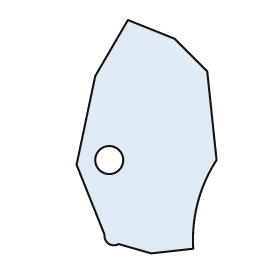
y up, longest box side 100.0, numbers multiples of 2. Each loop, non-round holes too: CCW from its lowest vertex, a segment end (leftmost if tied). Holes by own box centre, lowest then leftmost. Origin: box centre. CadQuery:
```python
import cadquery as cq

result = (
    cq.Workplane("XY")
    .moveTo(2.0, -50.0)
    .lineTo(20.0, -48.0)
    .threePointArc((22.0, -28.0), (30.0, -10.0))
    .lineTo(26.0, 28.0)
    .lineTo(12.0, 42.0)
    .lineTo(-8.0, 50.0)
    .lineTo(-22.0, 26.0)
    .lineTo(-30.0, -12.0)
    .lineTo(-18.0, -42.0)
    .threePointArc((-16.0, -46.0), (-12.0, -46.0))
    .close()
    .moveTo(-16.0, -10.0)
    .circle(6.0)
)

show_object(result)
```